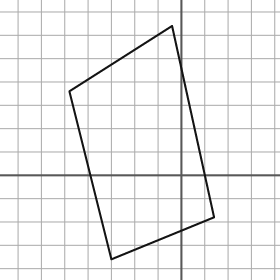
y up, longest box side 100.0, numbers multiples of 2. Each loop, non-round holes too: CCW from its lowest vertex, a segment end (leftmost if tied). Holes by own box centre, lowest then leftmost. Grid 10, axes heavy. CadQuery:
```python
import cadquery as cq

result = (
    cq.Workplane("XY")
    .moveTo(-30.0, -36.0)
    .lineTo(14.0, -18.0)
    .lineTo(-4.0, 64.0)
    .lineTo(-48.0, 36.0)
    .close()
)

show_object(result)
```